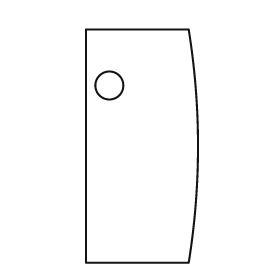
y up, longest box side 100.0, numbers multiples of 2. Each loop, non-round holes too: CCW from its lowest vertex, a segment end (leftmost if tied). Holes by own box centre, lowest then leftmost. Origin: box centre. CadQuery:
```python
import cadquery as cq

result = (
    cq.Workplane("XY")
    .moveTo(-24.0, -50.0)
    .lineTo(20.0, -50.0)
    .threePointArc((24.0, 0.0), (20.0, 50.0))
    .lineTo(-24.0, 50.0)
    .close()
    .moveTo(-14.0, 26.0)
    .circle(6.0)
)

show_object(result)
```